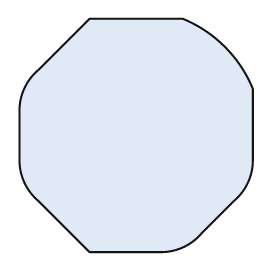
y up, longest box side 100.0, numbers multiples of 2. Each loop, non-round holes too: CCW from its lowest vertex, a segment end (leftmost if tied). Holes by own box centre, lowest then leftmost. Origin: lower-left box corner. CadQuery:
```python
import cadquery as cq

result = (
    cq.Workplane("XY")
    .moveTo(30.0, 0.0)
    .lineTo(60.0, 0.0)
    .threePointArc((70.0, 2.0), (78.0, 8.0))
    .lineTo(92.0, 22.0)
    .threePointArc((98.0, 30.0), (100.0, 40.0))
    .lineTo(100.0, 70.0)
    .threePointArc((88.0, 88.0), (70.0, 100.0))
    .lineTo(30.0, 100.0)
    .lineTo(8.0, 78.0)
    .threePointArc((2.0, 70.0), (0.0, 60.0))
    .lineTo(0.0, 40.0)
    .threePointArc((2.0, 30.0), (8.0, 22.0))
    .close()
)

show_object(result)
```